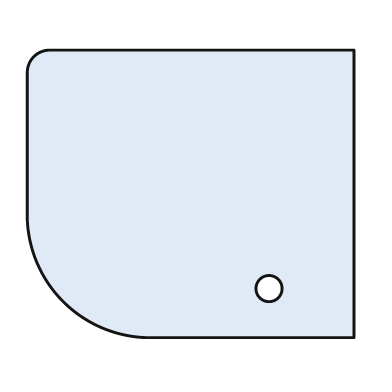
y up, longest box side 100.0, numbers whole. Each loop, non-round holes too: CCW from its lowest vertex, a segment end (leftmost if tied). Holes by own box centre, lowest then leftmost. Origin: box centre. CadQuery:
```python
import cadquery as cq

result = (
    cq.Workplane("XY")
    .moveTo(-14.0, -44.0)
    .lineTo(50.0, -44.0)
    .lineTo(50.0, 44.0)
    .lineTo(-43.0, 44.0)
    .threePointArc((-48.0, 42.0), (-50.0, 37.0))
    .lineTo(-50.0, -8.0)
    .threePointArc((-39.0, -33.0), (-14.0, -44.0))
    .close()
    .moveTo(24.0, -29.0)
    .circle(4.0)
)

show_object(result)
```